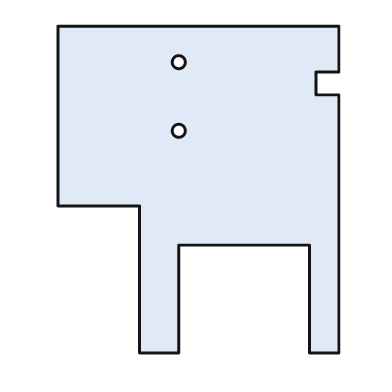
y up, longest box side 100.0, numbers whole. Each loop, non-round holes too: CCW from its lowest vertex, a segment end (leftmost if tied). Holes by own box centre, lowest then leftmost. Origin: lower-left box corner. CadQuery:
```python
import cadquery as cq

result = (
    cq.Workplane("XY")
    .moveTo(25.0, 0.0)
    .lineTo(37.0, 0.0)
    .lineTo(37.0, 33.0)
    .lineTo(77.0, 33.0)
    .lineTo(77.0, 0.0)
    .lineTo(86.0, 0.0)
    .lineTo(86.0, 79.0)
    .lineTo(79.0, 79.0)
    .lineTo(79.0, 86.0)
    .lineTo(86.0, 86.0)
    .lineTo(86.0, 100.0)
    .lineTo(0.0, 100.0)
    .lineTo(0.0, 45.0)
    .lineTo(25.0, 45.0)
    .close()
    .moveTo(37.0, 68.0)
    .circle(2.0)
    .moveTo(37.0, 89.0)
    .circle(2.0)
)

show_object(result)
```